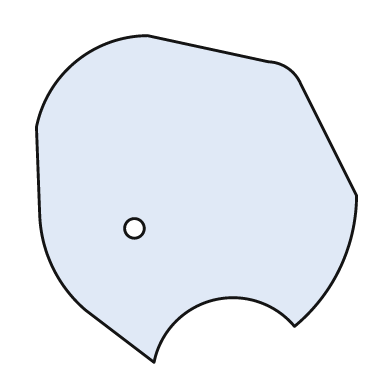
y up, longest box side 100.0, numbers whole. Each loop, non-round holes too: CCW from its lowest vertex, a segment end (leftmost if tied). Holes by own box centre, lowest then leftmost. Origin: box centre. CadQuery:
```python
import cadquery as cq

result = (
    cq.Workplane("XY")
    .moveTo(-13.0, -50.0)
    .threePointArc((5.0, -31.0), (30.0, -39.0))
    .threePointArc((44.0, -21.0), (49.0, 1.0))
    .lineTo(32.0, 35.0)
    .threePointArc((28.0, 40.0), (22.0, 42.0))
    .lineTo(-15.0, 50.0)
    .threePointArc((-37.0, 42.0), (-49.0, 22.0))
    .lineTo(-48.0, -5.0)
    .threePointArc((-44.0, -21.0), (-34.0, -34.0))
    .close()
    .moveTo(-19.0, -9.0)
    .circle(3.0)
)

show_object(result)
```